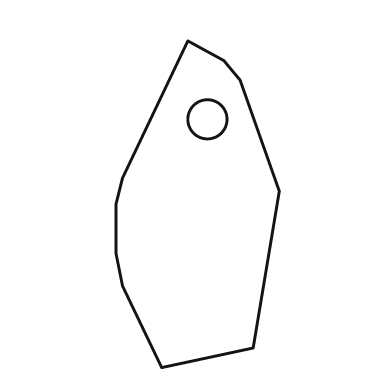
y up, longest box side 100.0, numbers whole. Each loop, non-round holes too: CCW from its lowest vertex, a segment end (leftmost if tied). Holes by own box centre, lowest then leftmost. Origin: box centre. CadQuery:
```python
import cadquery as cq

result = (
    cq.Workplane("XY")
    .moveTo(-11.0, -50.0)
    .lineTo(17.0, -44.0)
    .lineTo(25.0, 4.0)
    .lineTo(13.0, 38.0)
    .lineTo(8.0, 44.0)
    .lineTo(-3.0, 50.0)
    .lineTo(-23.0, 8.0)
    .lineTo(-25.0, 0.0)
    .lineTo(-25.0, -15.0)
    .lineTo(-23.0, -25.0)
    .close()
    .moveTo(3.0, 26.0)
    .circle(6.0)
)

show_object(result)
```